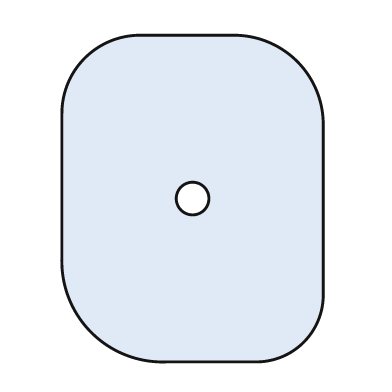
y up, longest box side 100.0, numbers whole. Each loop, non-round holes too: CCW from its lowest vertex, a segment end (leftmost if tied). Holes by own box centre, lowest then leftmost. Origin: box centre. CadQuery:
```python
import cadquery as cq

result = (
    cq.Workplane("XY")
    .moveTo(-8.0, -50.0)
    .lineTo(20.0, -50.0)
    .threePointArc((34.0, -44.0), (40.0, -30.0))
    .lineTo(40.0, 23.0)
    .threePointArc((32.0, 42.0), (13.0, 50.0))
    .lineTo(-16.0, 50.0)
    .threePointArc((-33.0, 43.0), (-40.0, 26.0))
    .lineTo(-40.0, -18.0)
    .threePointArc((-31.0, -41.0), (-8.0, -50.0))
    .close()
    .moveTo(0.0, 0.0)
    .circle(5.0)
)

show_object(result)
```